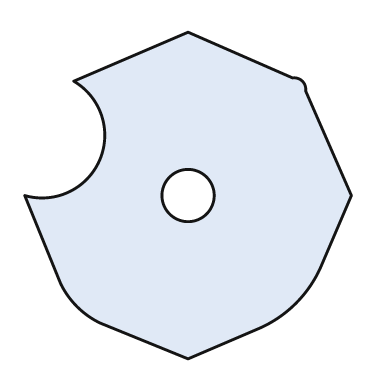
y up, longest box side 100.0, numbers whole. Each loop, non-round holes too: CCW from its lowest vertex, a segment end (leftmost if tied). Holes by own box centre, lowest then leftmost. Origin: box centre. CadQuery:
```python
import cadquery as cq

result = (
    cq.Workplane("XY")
    .moveTo(0.0, -50.0)
    .lineTo(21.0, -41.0)
    .threePointArc((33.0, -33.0), (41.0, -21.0))
    .lineTo(50.0, 0.0)
    .lineTo(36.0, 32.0)
    .threePointArc((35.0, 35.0), (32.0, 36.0))
    .lineTo(0.0, 50.0)
    .lineTo(-35.0, 35.0)
    .threePointArc((-27.0, 11.0), (-50.0, 0.0))
    .lineTo(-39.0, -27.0)
    .threePointArc((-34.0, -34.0), (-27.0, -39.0))
    .close()
    .moveTo(0.0, 0.0)
    .circle(8.0)
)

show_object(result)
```